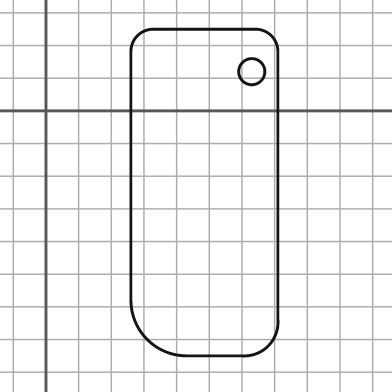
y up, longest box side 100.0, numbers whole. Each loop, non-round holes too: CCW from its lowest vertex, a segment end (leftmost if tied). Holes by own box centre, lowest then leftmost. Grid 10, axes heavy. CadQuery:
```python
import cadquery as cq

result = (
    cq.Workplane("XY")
    .moveTo(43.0, -75.0)
    .lineTo(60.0, -75.0)
    .threePointArc((68.0, -72.0), (71.0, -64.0))
    .lineTo(71.0, 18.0)
    .threePointArc((69.0, 23.0), (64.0, 25.0))
    .lineTo(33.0, 25.0)
    .threePointArc((28.0, 23.0), (26.0, 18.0))
    .lineTo(26.0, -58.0)
    .threePointArc((31.0, -70.0), (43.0, -75.0))
    .close()
    .moveTo(63.0, 12.0)
    .circle(4.0)
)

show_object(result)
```